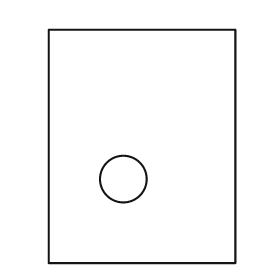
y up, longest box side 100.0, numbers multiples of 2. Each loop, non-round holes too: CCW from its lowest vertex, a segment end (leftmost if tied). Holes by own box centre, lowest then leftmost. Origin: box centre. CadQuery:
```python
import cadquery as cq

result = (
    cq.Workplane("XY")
    .moveTo(-40.0, -50.0)
    .lineTo(40.0, -50.0)
    .lineTo(40.0, 50.0)
    .lineTo(-40.0, 50.0)
    .close()
    .moveTo(-8.0, -14.0)
    .circle(10.0)
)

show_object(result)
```